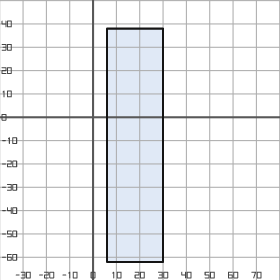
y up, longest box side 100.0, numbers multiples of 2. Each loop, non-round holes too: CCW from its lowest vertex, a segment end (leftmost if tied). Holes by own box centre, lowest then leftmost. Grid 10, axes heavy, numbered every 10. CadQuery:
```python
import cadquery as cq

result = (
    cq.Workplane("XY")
    .moveTo(6.0, -62.0)
    .lineTo(30.0, -62.0)
    .lineTo(30.0, 38.0)
    .lineTo(6.0, 38.0)
    .close()
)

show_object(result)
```